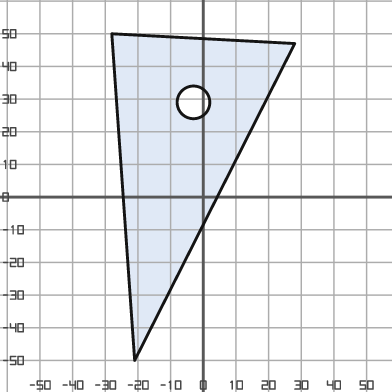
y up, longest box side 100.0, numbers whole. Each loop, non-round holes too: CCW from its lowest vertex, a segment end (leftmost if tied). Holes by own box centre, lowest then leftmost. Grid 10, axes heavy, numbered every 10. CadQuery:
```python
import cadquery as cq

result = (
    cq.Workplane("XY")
    .moveTo(-21.0, -50.0)
    .lineTo(28.0, 47.0)
    .lineTo(-28.0, 50.0)
    .close()
    .moveTo(-3.0, 29.0)
    .circle(5.0)
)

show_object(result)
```